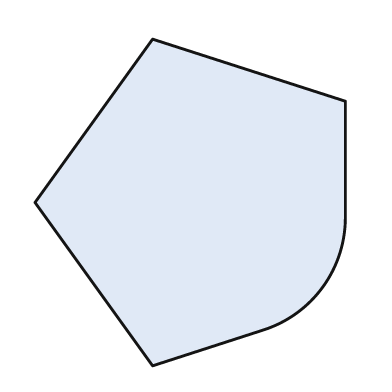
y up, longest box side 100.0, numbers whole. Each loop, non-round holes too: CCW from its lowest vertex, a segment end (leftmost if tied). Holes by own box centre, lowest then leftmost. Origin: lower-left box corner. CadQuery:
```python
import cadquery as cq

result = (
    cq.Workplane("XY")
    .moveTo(36.0, 0.0)
    .lineTo(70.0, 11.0)
    .threePointArc((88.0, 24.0), (95.0, 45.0))
    .lineTo(95.0, 81.0)
    .lineTo(36.0, 100.0)
    .lineTo(0.0, 50.0)
    .close()
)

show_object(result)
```